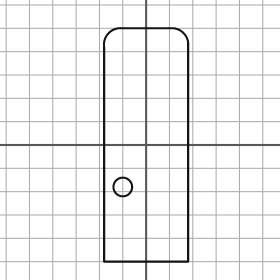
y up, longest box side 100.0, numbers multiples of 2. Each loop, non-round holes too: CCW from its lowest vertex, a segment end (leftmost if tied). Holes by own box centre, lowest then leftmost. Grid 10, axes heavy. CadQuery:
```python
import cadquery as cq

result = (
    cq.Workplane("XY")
    .moveTo(-18.0, -50.0)
    .lineTo(18.0, -50.0)
    .lineTo(18.0, 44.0)
    .threePointArc((16.0, 48.0), (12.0, 50.0))
    .lineTo(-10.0, 50.0)
    .threePointArc((-16.0, 48.0), (-18.0, 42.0))
    .close()
    .moveTo(-10.0, -18.0)
    .circle(4.0)
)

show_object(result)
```